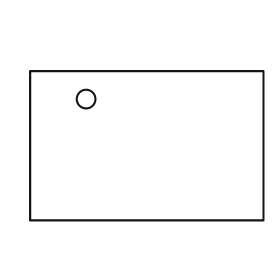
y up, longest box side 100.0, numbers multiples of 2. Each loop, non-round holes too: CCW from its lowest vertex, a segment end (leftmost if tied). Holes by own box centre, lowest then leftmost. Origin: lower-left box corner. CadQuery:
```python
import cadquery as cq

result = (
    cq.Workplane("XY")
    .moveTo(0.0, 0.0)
    .lineTo(100.0, 0.0)
    .lineTo(100.0, 64.0)
    .lineTo(0.0, 64.0)
    .close()
    .moveTo(24.0, 52.0)
    .circle(4.0)
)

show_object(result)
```